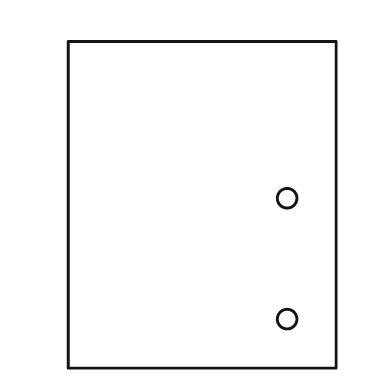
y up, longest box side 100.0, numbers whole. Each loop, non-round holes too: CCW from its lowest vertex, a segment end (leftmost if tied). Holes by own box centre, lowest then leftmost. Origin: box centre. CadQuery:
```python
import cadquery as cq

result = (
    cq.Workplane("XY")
    .moveTo(-41.0, -50.0)
    .lineTo(41.0, -50.0)
    .lineTo(41.0, 50.0)
    .lineTo(-41.0, 50.0)
    .close()
    .moveTo(26.0, -35.0)
    .circle(3.0)
    .moveTo(26.0, 2.0)
    .circle(3.0)
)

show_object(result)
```